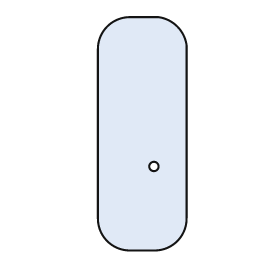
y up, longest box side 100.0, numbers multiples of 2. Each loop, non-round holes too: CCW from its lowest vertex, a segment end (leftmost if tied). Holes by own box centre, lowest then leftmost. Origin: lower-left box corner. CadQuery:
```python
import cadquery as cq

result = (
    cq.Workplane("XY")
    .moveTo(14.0, 0.0)
    .lineTo(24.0, 0.0)
    .threePointArc((34.0, 4.0), (38.0, 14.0))
    .lineTo(38.0, 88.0)
    .threePointArc((34.0, 96.0), (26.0, 100.0))
    .lineTo(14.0, 100.0)
    .threePointArc((4.0, 96.0), (0.0, 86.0))
    .lineTo(0.0, 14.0)
    .threePointArc((4.0, 4.0), (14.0, 0.0))
    .close()
    .moveTo(24.0, 36.0)
    .circle(2.0)
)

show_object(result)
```